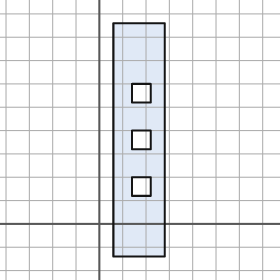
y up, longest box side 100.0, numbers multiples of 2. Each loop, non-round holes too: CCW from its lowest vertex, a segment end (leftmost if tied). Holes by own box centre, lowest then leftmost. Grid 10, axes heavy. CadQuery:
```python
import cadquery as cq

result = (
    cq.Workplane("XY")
    .moveTo(6.0, -14.0)
    .lineTo(28.0, -14.0)
    .lineTo(28.0, 86.0)
    .lineTo(6.0, 86.0)
    .close()
    .moveTo(14.0, 12.0)
    .lineTo(22.0, 12.0)
    .lineTo(22.0, 20.0)
    .lineTo(14.0, 20.0)
    .close()
    .moveTo(14.0, 32.0)
    .lineTo(22.0, 32.0)
    .lineTo(22.0, 40.0)
    .lineTo(14.0, 40.0)
    .close()
    .moveTo(14.0, 52.0)
    .lineTo(22.0, 52.0)
    .lineTo(22.0, 60.0)
    .lineTo(14.0, 60.0)
    .close()
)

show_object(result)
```